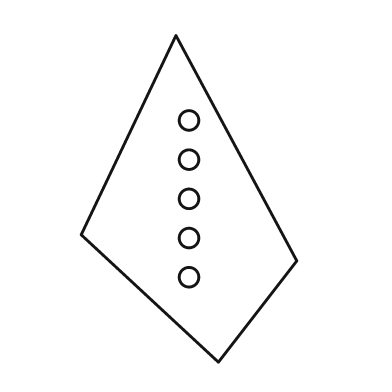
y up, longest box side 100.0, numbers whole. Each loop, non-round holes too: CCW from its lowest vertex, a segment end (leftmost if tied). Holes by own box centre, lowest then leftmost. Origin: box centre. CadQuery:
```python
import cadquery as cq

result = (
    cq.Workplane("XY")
    .moveTo(9.0, -50.0)
    .lineTo(33.0, -19.0)
    .lineTo(-4.0, 50.0)
    .lineTo(-33.0, -11.0)
    .close()
    .moveTo(0.0, -24.0)
    .circle(3.0)
    .moveTo(0.0, -12.0)
    .circle(3.0)
    .moveTo(0.0, 0.0)
    .circle(3.0)
    .moveTo(0.0, 12.0)
    .circle(3.0)
    .moveTo(0.0, 24.0)
    .circle(3.0)
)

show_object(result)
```